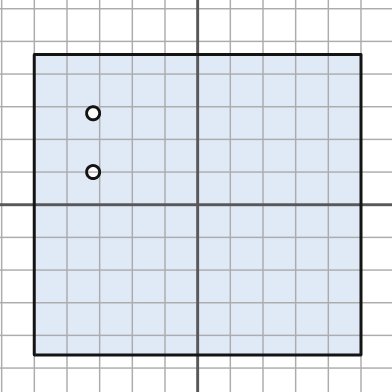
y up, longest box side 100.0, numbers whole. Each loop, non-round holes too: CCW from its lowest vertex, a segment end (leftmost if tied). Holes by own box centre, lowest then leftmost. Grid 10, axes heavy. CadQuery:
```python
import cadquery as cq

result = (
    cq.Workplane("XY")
    .moveTo(-50.0, -46.0)
    .lineTo(50.0, -46.0)
    .lineTo(50.0, 46.0)
    .lineTo(-50.0, 46.0)
    .close()
    .moveTo(-32.0, 10.0)
    .circle(2.0)
    .moveTo(-32.0, 28.0)
    .circle(2.0)
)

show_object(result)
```